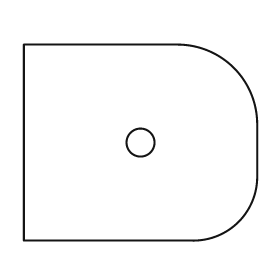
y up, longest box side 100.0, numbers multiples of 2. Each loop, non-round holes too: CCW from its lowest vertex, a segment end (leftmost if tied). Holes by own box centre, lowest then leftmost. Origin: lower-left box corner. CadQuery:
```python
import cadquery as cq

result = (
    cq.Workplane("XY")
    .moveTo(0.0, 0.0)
    .lineTo(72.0, 0.0)
    .threePointArc((92.0, 8.0), (100.0, 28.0))
    .lineTo(100.0, 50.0)
    .threePointArc((90.0, 74.0), (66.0, 84.0))
    .lineTo(0.0, 84.0)
    .close()
    .moveTo(50.0, 42.0)
    .circle(6.0)
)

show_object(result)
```